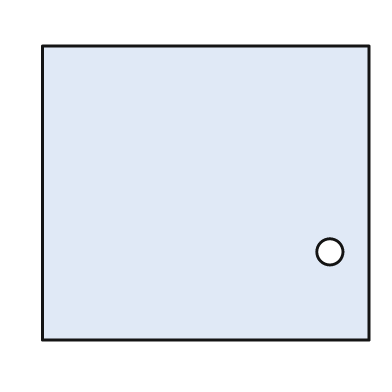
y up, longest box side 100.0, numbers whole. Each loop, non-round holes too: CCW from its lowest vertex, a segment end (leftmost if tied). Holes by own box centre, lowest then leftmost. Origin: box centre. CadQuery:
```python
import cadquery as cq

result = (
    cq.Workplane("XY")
    .moveTo(-50.0, -45.0)
    .lineTo(50.0, -45.0)
    .lineTo(50.0, 45.0)
    .lineTo(-50.0, 45.0)
    .close()
    .moveTo(38.0, -18.0)
    .circle(4.0)
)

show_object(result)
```